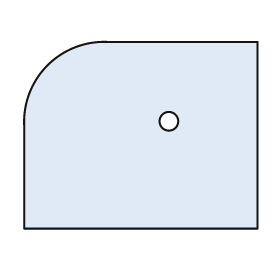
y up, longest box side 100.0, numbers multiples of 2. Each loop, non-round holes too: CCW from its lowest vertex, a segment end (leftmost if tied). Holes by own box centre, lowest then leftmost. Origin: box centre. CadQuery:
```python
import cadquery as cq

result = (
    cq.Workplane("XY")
    .moveTo(-50.0, -40.0)
    .lineTo(50.0, -40.0)
    .lineTo(50.0, 40.0)
    .lineTo(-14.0, 40.0)
    .threePointArc((-40.0, 30.0), (-50.0, 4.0))
    .close()
    .moveTo(12.0, 6.0)
    .circle(4.0)
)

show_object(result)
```